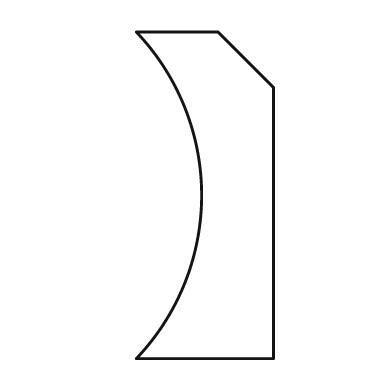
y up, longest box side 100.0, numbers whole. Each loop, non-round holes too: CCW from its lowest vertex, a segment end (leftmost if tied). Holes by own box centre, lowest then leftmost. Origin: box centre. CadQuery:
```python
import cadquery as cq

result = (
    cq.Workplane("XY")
    .moveTo(-21.0, -50.0)
    .lineTo(21.0, -50.0)
    .lineTo(21.0, 33.0)
    .lineTo(4.0, 50.0)
    .lineTo(-21.0, 50.0)
    .threePointArc((-1.0, 0.0), (-21.0, -50.0))
    .close()
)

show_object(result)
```